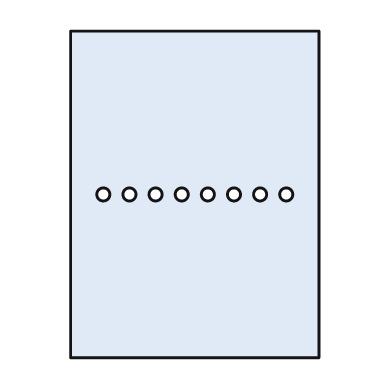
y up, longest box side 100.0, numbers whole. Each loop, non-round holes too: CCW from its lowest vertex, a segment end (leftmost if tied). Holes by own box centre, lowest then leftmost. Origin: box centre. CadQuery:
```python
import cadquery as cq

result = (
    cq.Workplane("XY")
    .moveTo(-38.0, -50.0)
    .lineTo(38.0, -50.0)
    .lineTo(38.0, 50.0)
    .lineTo(-38.0, 50.0)
    .close()
    .moveTo(-28.0, 0.0)
    .circle(2.0)
    .moveTo(-20.0, 0.0)
    .circle(2.0)
    .moveTo(-12.0, 0.0)
    .circle(2.0)
    .moveTo(-4.0, 0.0)
    .circle(2.0)
    .moveTo(4.0, 0.0)
    .circle(2.0)
    .moveTo(12.0, 0.0)
    .circle(2.0)
    .moveTo(20.0, 0.0)
    .circle(2.0)
    .moveTo(28.0, 0.0)
    .circle(2.0)
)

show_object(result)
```